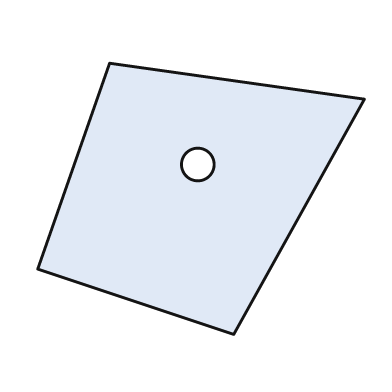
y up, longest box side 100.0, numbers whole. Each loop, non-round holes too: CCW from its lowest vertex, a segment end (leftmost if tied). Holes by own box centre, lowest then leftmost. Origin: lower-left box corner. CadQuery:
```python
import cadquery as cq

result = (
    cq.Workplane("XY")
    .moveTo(60.0, 0.0)
    .lineTo(100.0, 72.0)
    .lineTo(22.0, 83.0)
    .lineTo(0.0, 20.0)
    .close()
    .moveTo(49.0, 52.0)
    .circle(5.0)
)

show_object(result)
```